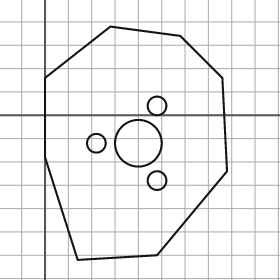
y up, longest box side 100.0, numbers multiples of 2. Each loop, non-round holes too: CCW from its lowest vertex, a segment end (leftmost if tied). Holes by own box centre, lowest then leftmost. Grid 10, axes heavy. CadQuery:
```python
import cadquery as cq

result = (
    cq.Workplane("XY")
    .moveTo(14.0, -62.0)
    .lineTo(48.0, -60.0)
    .lineTo(78.0, -24.0)
    .lineTo(76.0, 16.0)
    .lineTo(58.0, 34.0)
    .lineTo(28.0, 38.0)
    .lineTo(0.0, 16.0)
    .lineTo(0.0, -18.0)
    .close()
    .moveTo(48.0, -28.0)
    .circle(4.0)
    .moveTo(22.0, -12.0)
    .circle(4.0)
    .moveTo(40.0, -12.0)
    .circle(10.0)
    .moveTo(48.0, 4.0)
    .circle(4.0)
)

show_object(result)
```